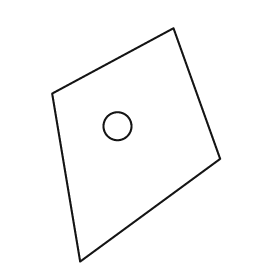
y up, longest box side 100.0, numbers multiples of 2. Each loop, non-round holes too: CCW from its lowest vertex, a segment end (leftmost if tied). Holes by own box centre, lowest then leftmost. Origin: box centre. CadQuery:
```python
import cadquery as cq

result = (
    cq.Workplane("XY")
    .moveTo(-24.0, -50.0)
    .lineTo(36.0, -6.0)
    .lineTo(16.0, 50.0)
    .lineTo(-36.0, 22.0)
    .close()
    .moveTo(-8.0, 8.0)
    .circle(6.0)
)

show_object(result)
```